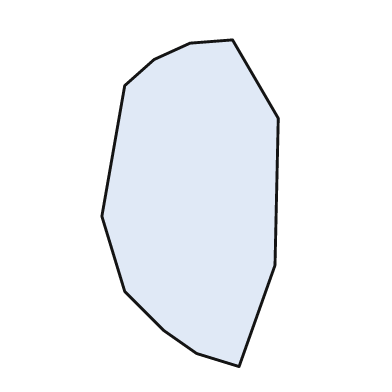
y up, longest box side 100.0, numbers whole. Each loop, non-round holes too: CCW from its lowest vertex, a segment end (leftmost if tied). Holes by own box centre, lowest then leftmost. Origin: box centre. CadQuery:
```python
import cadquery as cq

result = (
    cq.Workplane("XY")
    .moveTo(15.0, -50.0)
    .lineTo(26.0, -19.0)
    .lineTo(27.0, 26.0)
    .lineTo(13.0, 50.0)
    .lineTo(0.0, 49.0)
    .lineTo(-11.0, 44.0)
    .lineTo(-20.0, 36.0)
    .lineTo(-27.0, -4.0)
    .lineTo(-20.0, -27.0)
    .lineTo(-8.0, -39.0)
    .lineTo(2.0, -46.0)
    .close()
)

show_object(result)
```